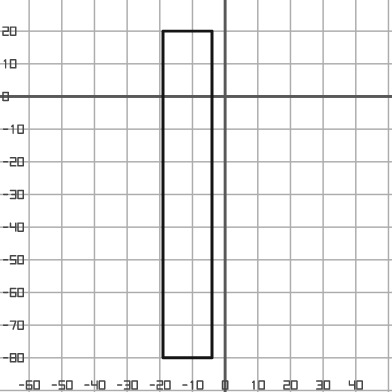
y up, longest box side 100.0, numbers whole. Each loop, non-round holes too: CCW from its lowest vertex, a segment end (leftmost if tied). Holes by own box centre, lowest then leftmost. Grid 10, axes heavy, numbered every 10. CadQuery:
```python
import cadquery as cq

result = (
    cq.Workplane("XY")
    .moveTo(-19.0, -80.0)
    .lineTo(-4.0, -80.0)
    .lineTo(-4.0, 20.0)
    .lineTo(-19.0, 20.0)
    .close()
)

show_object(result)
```